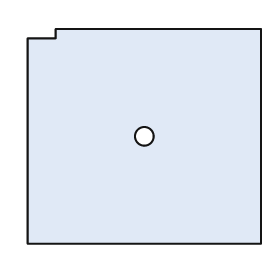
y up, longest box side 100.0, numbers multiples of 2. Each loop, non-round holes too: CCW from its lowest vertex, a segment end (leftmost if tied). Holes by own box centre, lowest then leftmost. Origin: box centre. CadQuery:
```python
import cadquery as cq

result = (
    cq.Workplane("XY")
    .moveTo(-50.0, -46.0)
    .lineTo(50.0, -46.0)
    .lineTo(50.0, 46.0)
    .lineTo(-38.0, 46.0)
    .lineTo(-38.0, 42.0)
    .lineTo(-50.0, 42.0)
    .close()
    .moveTo(0.0, 0.0)
    .circle(4.0)
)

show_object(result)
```